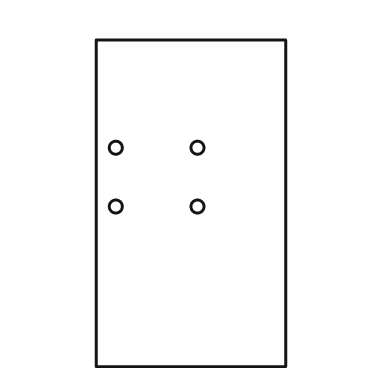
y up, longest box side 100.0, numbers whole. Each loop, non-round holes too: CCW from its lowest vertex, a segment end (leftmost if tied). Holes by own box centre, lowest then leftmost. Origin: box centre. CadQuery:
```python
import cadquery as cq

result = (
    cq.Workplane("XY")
    .moveTo(-29.0, -50.0)
    .lineTo(29.0, -50.0)
    .lineTo(29.0, 50.0)
    .lineTo(-29.0, 50.0)
    .close()
    .moveTo(-23.0, -1.0)
    .circle(2.0)
    .moveTo(2.0, -1.0)
    .circle(2.0)
    .moveTo(-23.0, 17.0)
    .circle(2.0)
    .moveTo(2.0, 17.0)
    .circle(2.0)
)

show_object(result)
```